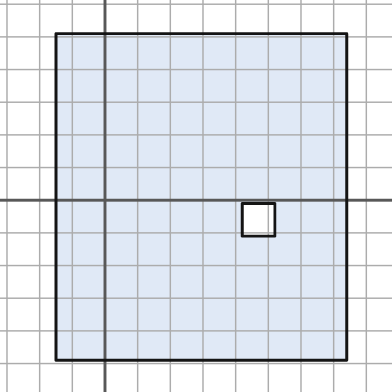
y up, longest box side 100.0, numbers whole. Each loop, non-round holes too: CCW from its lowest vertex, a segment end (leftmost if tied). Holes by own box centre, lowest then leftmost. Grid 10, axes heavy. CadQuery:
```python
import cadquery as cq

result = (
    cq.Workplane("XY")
    .moveTo(-15.0, -49.0)
    .lineTo(74.0, -49.0)
    .lineTo(74.0, 51.0)
    .lineTo(-15.0, 51.0)
    .close()
    .moveTo(42.0, -11.0)
    .lineTo(52.0, -11.0)
    .lineTo(52.0, -1.0)
    .lineTo(42.0, -1.0)
    .close()
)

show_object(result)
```